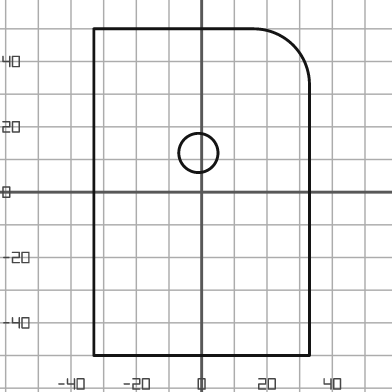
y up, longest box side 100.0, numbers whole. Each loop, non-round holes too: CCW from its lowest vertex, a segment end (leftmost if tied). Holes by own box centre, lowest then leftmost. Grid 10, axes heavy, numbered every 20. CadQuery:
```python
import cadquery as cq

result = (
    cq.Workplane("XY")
    .moveTo(-33.0, -50.0)
    .lineTo(33.0, -50.0)
    .lineTo(33.0, 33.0)
    .threePointArc((28.0, 45.0), (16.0, 50.0))
    .lineTo(-33.0, 50.0)
    .close()
    .moveTo(-1.0, 12.0)
    .circle(6.0)
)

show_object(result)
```